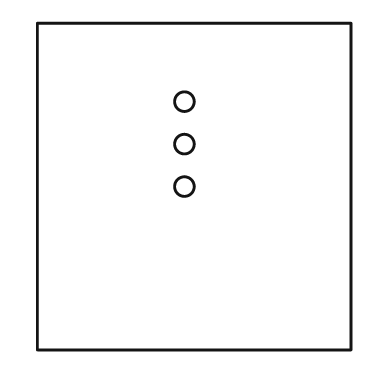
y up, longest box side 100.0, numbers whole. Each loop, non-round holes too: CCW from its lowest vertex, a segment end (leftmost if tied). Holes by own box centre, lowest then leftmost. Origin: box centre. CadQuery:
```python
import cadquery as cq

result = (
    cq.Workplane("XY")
    .moveTo(-48.0, -50.0)
    .lineTo(48.0, -50.0)
    .lineTo(48.0, 50.0)
    .lineTo(-48.0, 50.0)
    .close()
    .moveTo(-3.0, 0.0)
    .circle(3.0)
    .moveTo(-3.0, 13.0)
    .circle(3.0)
    .moveTo(-3.0, 26.0)
    .circle(3.0)
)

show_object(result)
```